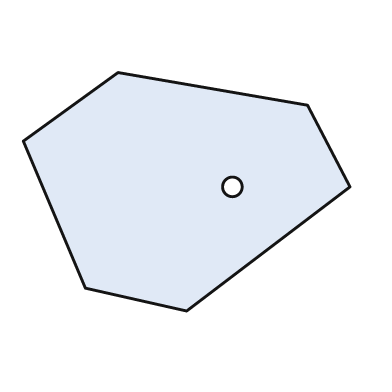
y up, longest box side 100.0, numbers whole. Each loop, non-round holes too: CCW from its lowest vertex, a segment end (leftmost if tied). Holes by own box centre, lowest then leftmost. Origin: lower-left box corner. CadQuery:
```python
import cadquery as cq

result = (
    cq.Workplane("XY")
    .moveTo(50.0, 0.0)
    .lineTo(100.0, 38.0)
    .lineTo(87.0, 63.0)
    .lineTo(29.0, 73.0)
    .lineTo(0.0, 52.0)
    .lineTo(19.0, 7.0)
    .close()
    .moveTo(64.0, 38.0)
    .circle(3.0)
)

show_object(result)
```